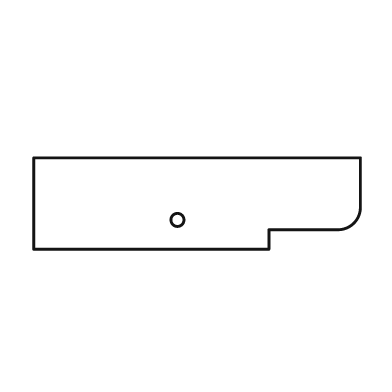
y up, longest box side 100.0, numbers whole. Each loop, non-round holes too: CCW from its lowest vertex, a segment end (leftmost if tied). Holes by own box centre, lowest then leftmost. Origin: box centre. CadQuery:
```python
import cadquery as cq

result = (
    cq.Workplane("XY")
    .moveTo(-50.0, -14.0)
    .lineTo(22.0, -14.0)
    .lineTo(22.0, -8.0)
    .lineTo(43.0, -8.0)
    .threePointArc((48.0, -6.0), (50.0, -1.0))
    .lineTo(50.0, 14.0)
    .lineTo(-50.0, 14.0)
    .close()
    .moveTo(-6.0, -5.0)
    .circle(2.0)
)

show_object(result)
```